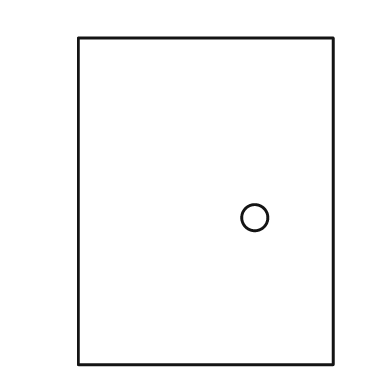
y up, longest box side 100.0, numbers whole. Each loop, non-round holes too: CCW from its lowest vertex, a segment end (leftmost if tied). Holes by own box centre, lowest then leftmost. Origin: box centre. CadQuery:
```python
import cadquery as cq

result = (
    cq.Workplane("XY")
    .moveTo(-39.0, -50.0)
    .lineTo(39.0, -50.0)
    .lineTo(39.0, 50.0)
    .lineTo(-39.0, 50.0)
    .close()
    .moveTo(15.0, -5.0)
    .circle(4.0)
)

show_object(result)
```